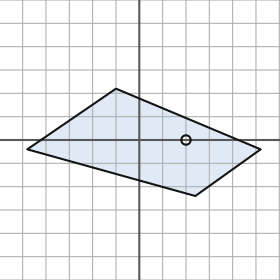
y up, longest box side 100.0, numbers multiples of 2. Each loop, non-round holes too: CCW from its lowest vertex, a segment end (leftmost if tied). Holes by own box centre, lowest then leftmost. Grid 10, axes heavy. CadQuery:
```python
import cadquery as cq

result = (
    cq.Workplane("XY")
    .moveTo(24.0, -24.0)
    .lineTo(52.0, -4.0)
    .lineTo(-10.0, 22.0)
    .lineTo(-48.0, -4.0)
    .close()
    .moveTo(20.0, 0.0)
    .circle(2.0)
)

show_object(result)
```